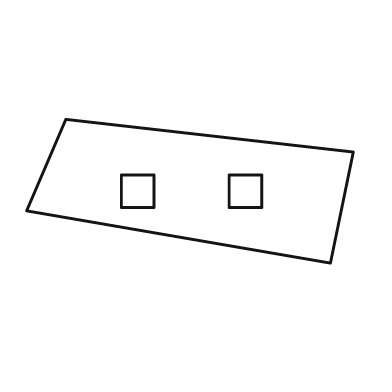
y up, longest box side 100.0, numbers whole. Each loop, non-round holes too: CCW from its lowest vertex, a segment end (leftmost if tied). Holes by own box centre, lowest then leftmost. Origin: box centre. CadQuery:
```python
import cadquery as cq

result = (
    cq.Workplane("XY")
    .moveTo(43.0, -22.0)
    .lineTo(50.0, 12.0)
    .lineTo(-38.0, 22.0)
    .lineTo(-50.0, -6.0)
    .close()
    .moveTo(-21.0, -5.0)
    .lineTo(-11.0, -5.0)
    .lineTo(-11.0, 5.0)
    .lineTo(-21.0, 5.0)
    .close()
    .moveTo(12.0, -5.0)
    .lineTo(22.0, -5.0)
    .lineTo(22.0, 5.0)
    .lineTo(12.0, 5.0)
    .close()
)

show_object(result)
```